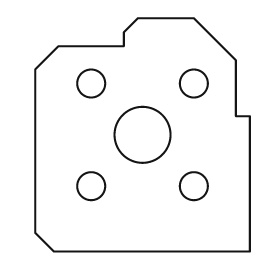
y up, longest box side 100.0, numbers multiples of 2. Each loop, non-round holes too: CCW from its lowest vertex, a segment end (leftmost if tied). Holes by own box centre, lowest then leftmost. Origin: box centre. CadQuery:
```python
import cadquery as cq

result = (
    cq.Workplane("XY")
    .moveTo(-38.0, -50.0)
    .lineTo(46.0, -50.0)
    .lineTo(46.0, 8.0)
    .lineTo(40.0, 8.0)
    .lineTo(40.0, 32.0)
    .lineTo(22.0, 50.0)
    .lineTo(-2.0, 50.0)
    .lineTo(-8.0, 44.0)
    .lineTo(-8.0, 38.0)
    .lineTo(-36.0, 38.0)
    .lineTo(-46.0, 28.0)
    .lineTo(-46.0, -42.0)
    .close()
    .moveTo(-22.0, -22.0)
    .circle(6.0)
    .moveTo(22.0, -22.0)
    .circle(6.0)
    .moveTo(0.0, 0.0)
    .circle(12.0)
    .moveTo(-22.0, 22.0)
    .circle(6.0)
    .moveTo(22.0, 22.0)
    .circle(6.0)
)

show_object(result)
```